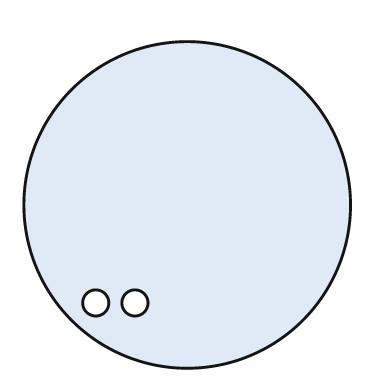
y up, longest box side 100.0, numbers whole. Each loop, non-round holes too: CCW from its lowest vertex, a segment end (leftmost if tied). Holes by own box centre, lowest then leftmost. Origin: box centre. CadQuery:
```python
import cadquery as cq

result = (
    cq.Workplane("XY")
    .moveTo(0.0, 0.0)
    .circle(50.0)
    .moveTo(-28.0, -30.0)
    .circle(4.0)
    .moveTo(-16.0, -30.0)
    .circle(4.0)
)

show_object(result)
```